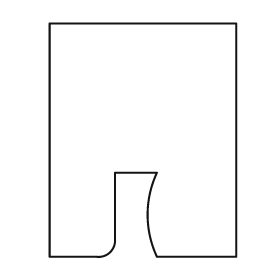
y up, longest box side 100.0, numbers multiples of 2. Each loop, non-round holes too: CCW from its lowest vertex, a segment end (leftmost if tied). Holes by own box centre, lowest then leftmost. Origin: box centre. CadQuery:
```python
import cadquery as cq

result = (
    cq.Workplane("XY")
    .moveTo(-40.0, -50.0)
    .lineTo(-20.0, -50.0)
    .threePointArc((-14.0, -48.0), (-12.0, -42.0))
    .lineTo(-12.0, -14.0)
    .lineTo(6.0, -14.0)
    .threePointArc((2.0, -32.0), (6.0, -50.0))
    .lineTo(40.0, -50.0)
    .lineTo(40.0, 50.0)
    .lineTo(-40.0, 50.0)
    .close()
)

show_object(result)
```